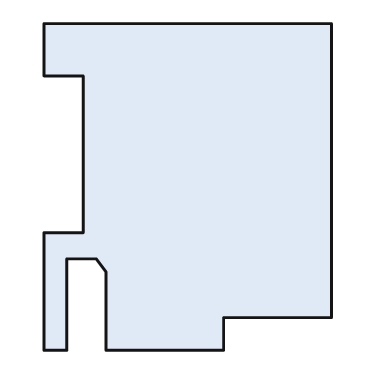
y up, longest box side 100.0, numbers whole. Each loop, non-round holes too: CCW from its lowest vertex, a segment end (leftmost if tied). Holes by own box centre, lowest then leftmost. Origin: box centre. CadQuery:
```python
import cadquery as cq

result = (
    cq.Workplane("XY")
    .moveTo(-44.0, -50.0)
    .lineTo(-37.0, -50.0)
    .lineTo(-37.0, -22.0)
    .lineTo(-28.0, -22.0)
    .lineTo(-25.0, -26.0)
    .lineTo(-25.0, -50.0)
    .lineTo(11.0, -50.0)
    .lineTo(11.0, -40.0)
    .lineTo(44.0, -40.0)
    .lineTo(44.0, 50.0)
    .lineTo(-44.0, 50.0)
    .lineTo(-44.0, 34.0)
    .lineTo(-32.0, 34.0)
    .lineTo(-32.0, -14.0)
    .lineTo(-44.0, -14.0)
    .close()
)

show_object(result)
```